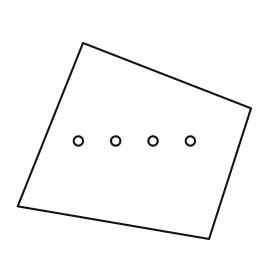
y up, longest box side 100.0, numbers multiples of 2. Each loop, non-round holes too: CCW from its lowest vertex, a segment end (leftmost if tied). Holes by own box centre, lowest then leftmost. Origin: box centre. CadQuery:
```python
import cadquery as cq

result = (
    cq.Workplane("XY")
    .moveTo(32.0, -42.0)
    .lineTo(50.0, 14.0)
    .lineTo(-22.0, 42.0)
    .lineTo(-50.0, -28.0)
    .close()
    .moveTo(-24.0, 0.0)
    .circle(2.0)
    .moveTo(-8.0, 0.0)
    .circle(2.0)
    .moveTo(8.0, 0.0)
    .circle(2.0)
    .moveTo(24.0, 0.0)
    .circle(2.0)
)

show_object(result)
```